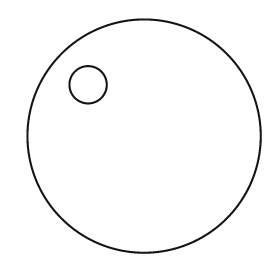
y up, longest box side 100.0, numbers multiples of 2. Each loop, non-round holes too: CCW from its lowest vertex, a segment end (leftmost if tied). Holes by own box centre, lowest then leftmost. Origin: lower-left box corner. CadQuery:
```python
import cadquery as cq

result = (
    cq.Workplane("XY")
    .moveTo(50.0, 50.0)
    .circle(50.0)
    .moveTo(26.0, 72.0)
    .circle(8.0)
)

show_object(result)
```